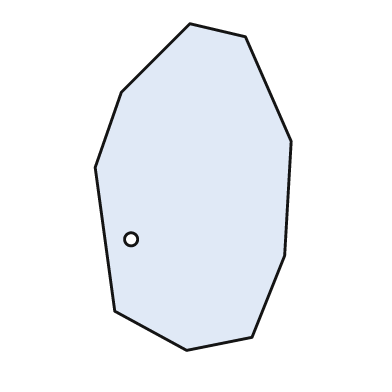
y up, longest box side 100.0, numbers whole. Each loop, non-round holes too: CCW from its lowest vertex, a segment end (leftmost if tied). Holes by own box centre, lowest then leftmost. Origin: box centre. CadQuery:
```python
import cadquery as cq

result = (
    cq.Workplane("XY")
    .moveTo(-2.0, -50.0)
    .lineTo(18.0, -46.0)
    .lineTo(28.0, -21.0)
    .lineTo(30.0, 14.0)
    .lineTo(16.0, 46.0)
    .lineTo(-1.0, 50.0)
    .lineTo(-22.0, 29.0)
    .lineTo(-30.0, 6.0)
    .lineTo(-24.0, -38.0)
    .close()
    .moveTo(-19.0, -16.0)
    .circle(2.0)
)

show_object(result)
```